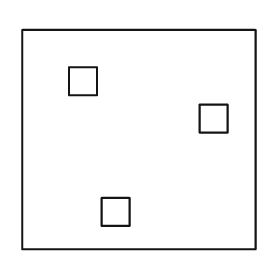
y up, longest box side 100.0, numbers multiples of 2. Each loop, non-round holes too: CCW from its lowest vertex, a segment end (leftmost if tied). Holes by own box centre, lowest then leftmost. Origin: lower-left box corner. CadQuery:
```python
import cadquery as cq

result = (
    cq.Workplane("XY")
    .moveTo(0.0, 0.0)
    .lineTo(100.0, 0.0)
    .lineTo(100.0, 94.0)
    .lineTo(0.0, 94.0)
    .close()
    .moveTo(34.0, 10.0)
    .lineTo(46.0, 10.0)
    .lineTo(46.0, 22.0)
    .lineTo(34.0, 22.0)
    .close()
    .moveTo(76.0, 50.0)
    .lineTo(88.0, 50.0)
    .lineTo(88.0, 62.0)
    .lineTo(76.0, 62.0)
    .close()
    .moveTo(20.0, 66.0)
    .lineTo(32.0, 66.0)
    .lineTo(32.0, 78.0)
    .lineTo(20.0, 78.0)
    .close()
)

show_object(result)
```